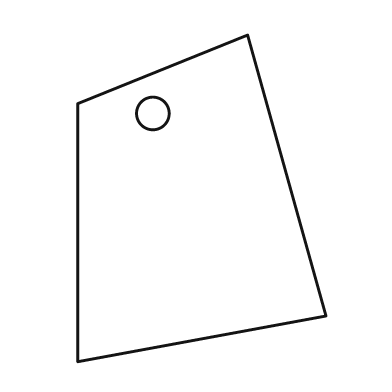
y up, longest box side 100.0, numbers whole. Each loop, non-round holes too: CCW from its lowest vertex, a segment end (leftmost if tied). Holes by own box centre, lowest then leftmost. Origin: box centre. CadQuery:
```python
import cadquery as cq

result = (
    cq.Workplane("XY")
    .moveTo(-38.0, -50.0)
    .lineTo(38.0, -36.0)
    .lineTo(14.0, 50.0)
    .lineTo(-38.0, 29.0)
    .close()
    .moveTo(-15.0, 26.0)
    .circle(5.0)
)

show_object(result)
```